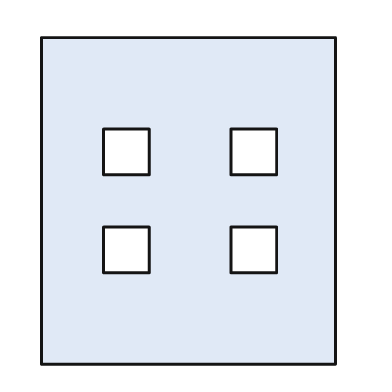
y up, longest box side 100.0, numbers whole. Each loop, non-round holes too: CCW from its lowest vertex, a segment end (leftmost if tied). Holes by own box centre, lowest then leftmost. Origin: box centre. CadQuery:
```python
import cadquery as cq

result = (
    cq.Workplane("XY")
    .moveTo(-45.0, -50.0)
    .lineTo(45.0, -50.0)
    .lineTo(45.0, 50.0)
    .lineTo(-45.0, 50.0)
    .close()
    .moveTo(-26.0, -22.0)
    .lineTo(-12.0, -22.0)
    .lineTo(-12.0, -8.0)
    .lineTo(-26.0, -8.0)
    .close()
    .moveTo(13.0, -22.0)
    .lineTo(27.0, -22.0)
    .lineTo(27.0, -8.0)
    .lineTo(13.0, -8.0)
    .close()
    .moveTo(-26.0, 8.0)
    .lineTo(-12.0, 8.0)
    .lineTo(-12.0, 22.0)
    .lineTo(-26.0, 22.0)
    .close()
    .moveTo(13.0, 8.0)
    .lineTo(27.0, 8.0)
    .lineTo(27.0, 22.0)
    .lineTo(13.0, 22.0)
    .close()
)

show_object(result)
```